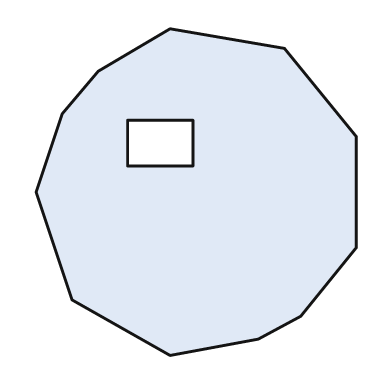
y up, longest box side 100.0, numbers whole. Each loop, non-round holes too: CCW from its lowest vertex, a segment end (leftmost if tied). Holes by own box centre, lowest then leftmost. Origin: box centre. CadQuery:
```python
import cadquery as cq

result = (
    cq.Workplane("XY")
    .moveTo(-8.0, -50.0)
    .lineTo(19.0, -45.0)
    .lineTo(32.0, -38.0)
    .lineTo(49.0, -17.0)
    .lineTo(49.0, 17.0)
    .lineTo(27.0, 44.0)
    .lineTo(-8.0, 50.0)
    .lineTo(-30.0, 37.0)
    .lineTo(-41.0, 24.0)
    .lineTo(-49.0, 0.0)
    .lineTo(-38.0, -33.0)
    .close()
    .moveTo(-21.0, 8.0)
    .lineTo(-1.0, 8.0)
    .lineTo(-1.0, 22.0)
    .lineTo(-21.0, 22.0)
    .close()
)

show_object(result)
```